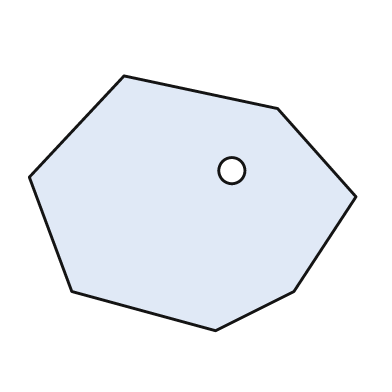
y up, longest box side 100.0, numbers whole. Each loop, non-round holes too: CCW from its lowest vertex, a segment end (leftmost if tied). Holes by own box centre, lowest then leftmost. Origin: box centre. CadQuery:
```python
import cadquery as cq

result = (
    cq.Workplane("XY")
    .moveTo(7.0, -39.0)
    .lineTo(31.0, -27.0)
    .lineTo(50.0, 2.0)
    .lineTo(26.0, 29.0)
    .lineTo(-21.0, 39.0)
    .lineTo(-50.0, 8.0)
    .lineTo(-37.0, -27.0)
    .close()
    .moveTo(12.0, 10.0)
    .circle(4.0)
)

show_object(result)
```